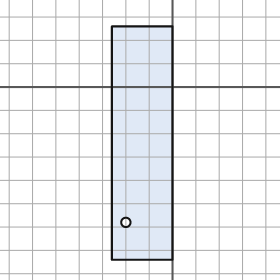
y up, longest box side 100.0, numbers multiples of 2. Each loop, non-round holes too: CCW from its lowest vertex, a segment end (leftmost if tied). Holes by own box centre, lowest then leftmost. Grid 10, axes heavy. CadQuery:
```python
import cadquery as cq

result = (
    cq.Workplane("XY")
    .moveTo(-26.0, -74.0)
    .lineTo(0.0, -74.0)
    .lineTo(0.0, 26.0)
    .lineTo(-26.0, 26.0)
    .close()
    .moveTo(-20.0, -58.0)
    .circle(2.0)
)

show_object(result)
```